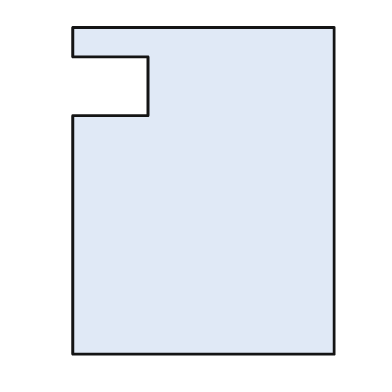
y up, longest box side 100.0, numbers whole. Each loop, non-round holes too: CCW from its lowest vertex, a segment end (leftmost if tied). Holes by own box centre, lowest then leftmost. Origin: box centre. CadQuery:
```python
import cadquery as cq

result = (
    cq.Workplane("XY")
    .moveTo(-40.0, -50.0)
    .lineTo(40.0, -50.0)
    .lineTo(40.0, 50.0)
    .lineTo(-40.0, 50.0)
    .lineTo(-40.0, 41.0)
    .lineTo(-17.0, 41.0)
    .lineTo(-17.0, 23.0)
    .lineTo(-40.0, 23.0)
    .close()
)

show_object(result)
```